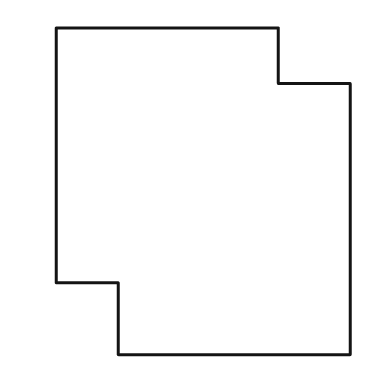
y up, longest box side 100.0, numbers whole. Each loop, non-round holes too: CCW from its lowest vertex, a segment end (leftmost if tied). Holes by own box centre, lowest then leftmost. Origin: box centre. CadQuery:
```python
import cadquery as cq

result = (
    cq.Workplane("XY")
    .moveTo(-26.0, -50.0)
    .lineTo(45.0, -50.0)
    .lineTo(45.0, 33.0)
    .lineTo(23.0, 33.0)
    .lineTo(23.0, 50.0)
    .lineTo(-45.0, 50.0)
    .lineTo(-45.0, -28.0)
    .lineTo(-26.0, -28.0)
    .close()
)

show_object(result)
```